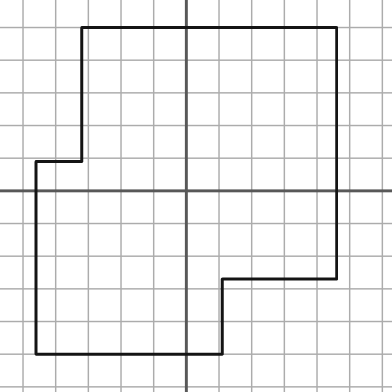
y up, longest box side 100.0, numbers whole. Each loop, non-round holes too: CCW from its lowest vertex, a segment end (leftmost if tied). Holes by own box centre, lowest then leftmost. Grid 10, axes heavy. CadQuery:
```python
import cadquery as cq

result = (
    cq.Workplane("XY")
    .moveTo(-46.0, -50.0)
    .lineTo(11.0, -50.0)
    .lineTo(11.0, -27.0)
    .lineTo(46.0, -27.0)
    .lineTo(46.0, 50.0)
    .lineTo(-32.0, 50.0)
    .lineTo(-32.0, 9.0)
    .lineTo(-46.0, 9.0)
    .close()
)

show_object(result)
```